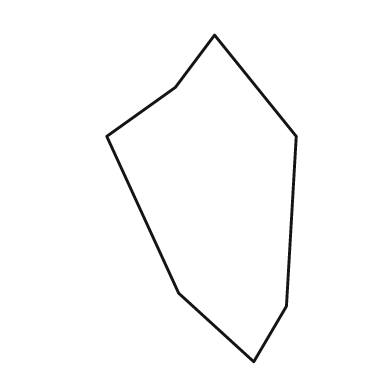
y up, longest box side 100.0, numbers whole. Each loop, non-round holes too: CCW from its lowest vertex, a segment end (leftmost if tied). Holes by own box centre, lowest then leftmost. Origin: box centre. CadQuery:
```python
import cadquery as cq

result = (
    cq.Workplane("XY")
    .moveTo(16.0, -50.0)
    .lineTo(26.0, -33.0)
    .lineTo(29.0, 19.0)
    .lineTo(4.0, 50.0)
    .lineTo(-8.0, 34.0)
    .lineTo(-29.0, 19.0)
    .lineTo(-7.0, -29.0)
    .close()
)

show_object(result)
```